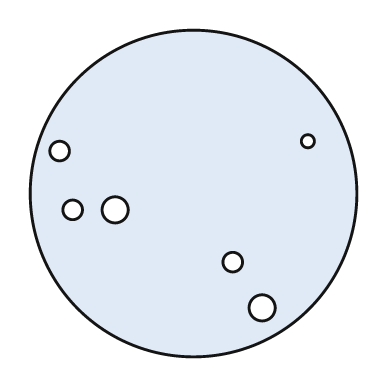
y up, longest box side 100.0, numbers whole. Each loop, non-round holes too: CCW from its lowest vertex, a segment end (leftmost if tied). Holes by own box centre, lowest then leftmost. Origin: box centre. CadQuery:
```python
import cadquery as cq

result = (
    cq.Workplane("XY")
    .moveTo(0.0, 0.0)
    .circle(50.0)
    .moveTo(21.0, -35.0)
    .circle(4.0)
    .moveTo(12.0, -21.0)
    .circle(3.0)
    .moveTo(-37.0, -5.0)
    .circle(3.0)
    .moveTo(-24.0, -5.0)
    .circle(4.0)
    .moveTo(-41.0, 13.0)
    .circle(3.0)
    .moveTo(35.0, 16.0)
    .circle(2.0)
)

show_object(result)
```